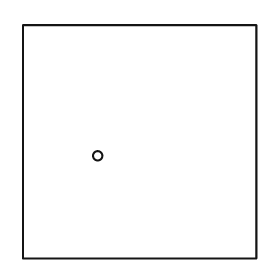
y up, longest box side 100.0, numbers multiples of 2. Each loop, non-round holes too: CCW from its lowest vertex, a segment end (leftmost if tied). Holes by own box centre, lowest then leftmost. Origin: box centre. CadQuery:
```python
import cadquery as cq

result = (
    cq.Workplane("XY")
    .moveTo(-50.0, -50.0)
    .lineTo(50.0, -50.0)
    .lineTo(50.0, 50.0)
    .lineTo(-50.0, 50.0)
    .close()
    .moveTo(-18.0, -6.0)
    .circle(2.0)
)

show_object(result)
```